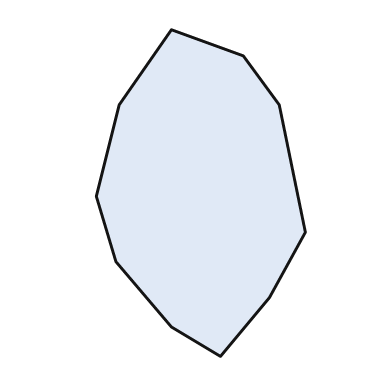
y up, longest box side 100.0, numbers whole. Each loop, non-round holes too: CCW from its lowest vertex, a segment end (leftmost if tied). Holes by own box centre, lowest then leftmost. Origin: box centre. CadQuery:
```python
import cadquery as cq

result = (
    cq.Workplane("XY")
    .moveTo(6.0, -50.0)
    .lineTo(21.0, -32.0)
    .lineTo(32.0, -12.0)
    .lineTo(24.0, 27.0)
    .lineTo(13.0, 42.0)
    .lineTo(-9.0, 50.0)
    .lineTo(-25.0, 27.0)
    .lineTo(-32.0, -1.0)
    .lineTo(-26.0, -21.0)
    .lineTo(-9.0, -41.0)
    .close()
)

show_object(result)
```